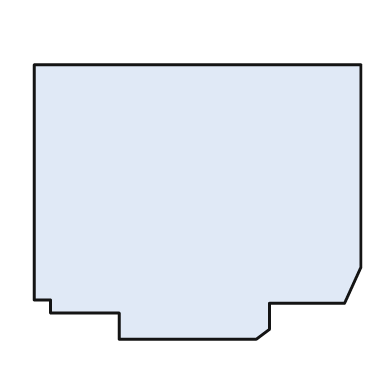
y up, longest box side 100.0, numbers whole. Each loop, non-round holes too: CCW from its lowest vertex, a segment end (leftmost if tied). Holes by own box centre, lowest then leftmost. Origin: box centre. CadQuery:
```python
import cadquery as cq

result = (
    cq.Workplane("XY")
    .moveTo(-24.0, -42.0)
    .lineTo(18.0, -42.0)
    .lineTo(22.0, -39.0)
    .lineTo(22.0, -31.0)
    .lineTo(45.0, -31.0)
    .lineTo(50.0, -20.0)
    .lineTo(50.0, 42.0)
    .lineTo(-50.0, 42.0)
    .lineTo(-50.0, -30.0)
    .lineTo(-45.0, -30.0)
    .lineTo(-45.0, -34.0)
    .lineTo(-24.0, -34.0)
    .close()
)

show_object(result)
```